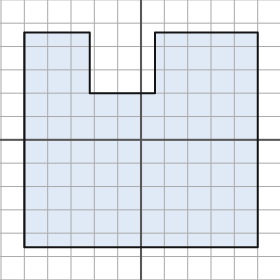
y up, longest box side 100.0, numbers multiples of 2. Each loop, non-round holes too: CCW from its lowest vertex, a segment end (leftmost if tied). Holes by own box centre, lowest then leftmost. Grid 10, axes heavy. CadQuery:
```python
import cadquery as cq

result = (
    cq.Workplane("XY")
    .moveTo(-50.0, -46.0)
    .lineTo(50.0, -46.0)
    .lineTo(50.0, 46.0)
    .lineTo(6.0, 46.0)
    .lineTo(6.0, 20.0)
    .lineTo(-22.0, 20.0)
    .lineTo(-22.0, 46.0)
    .lineTo(-50.0, 46.0)
    .close()
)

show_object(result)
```